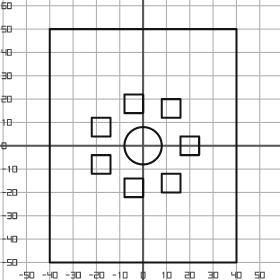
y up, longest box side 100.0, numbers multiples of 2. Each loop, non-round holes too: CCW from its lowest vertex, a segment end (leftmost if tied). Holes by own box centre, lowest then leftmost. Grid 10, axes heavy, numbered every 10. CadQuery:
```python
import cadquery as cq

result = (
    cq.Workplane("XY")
    .moveTo(-40.0, -50.0)
    .lineTo(40.0, -50.0)
    .lineTo(40.0, 50.0)
    .lineTo(-40.0, 50.0)
    .close()
    .moveTo(-8.0, -22.0)
    .lineTo(0.0, -22.0)
    .lineTo(0.0, -14.0)
    .lineTo(-8.0, -14.0)
    .close()
    .moveTo(8.0, -20.0)
    .lineTo(16.0, -20.0)
    .lineTo(16.0, -12.0)
    .lineTo(8.0, -12.0)
    .close()
    .moveTo(-22.0, -12.0)
    .lineTo(-14.0, -12.0)
    .lineTo(-14.0, -4.0)
    .lineTo(-22.0, -4.0)
    .close()
    .moveTo(0.0, 0.0)
    .circle(8.0)
    .moveTo(16.0, -4.0)
    .lineTo(24.0, -4.0)
    .lineTo(24.0, 4.0)
    .lineTo(16.0, 4.0)
    .close()
    .moveTo(-22.0, 4.0)
    .lineTo(-14.0, 4.0)
    .lineTo(-14.0, 12.0)
    .lineTo(-22.0, 12.0)
    .close()
    .moveTo(8.0, 12.0)
    .lineTo(16.0, 12.0)
    .lineTo(16.0, 20.0)
    .lineTo(8.0, 20.0)
    .close()
    .moveTo(-8.0, 14.0)
    .lineTo(0.0, 14.0)
    .lineTo(0.0, 22.0)
    .lineTo(-8.0, 22.0)
    .close()
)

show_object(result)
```